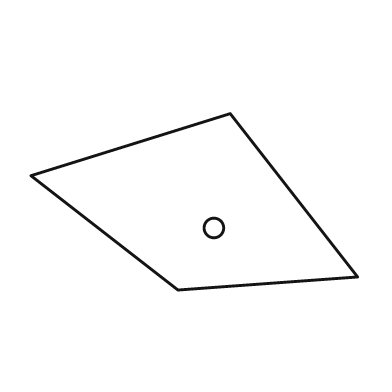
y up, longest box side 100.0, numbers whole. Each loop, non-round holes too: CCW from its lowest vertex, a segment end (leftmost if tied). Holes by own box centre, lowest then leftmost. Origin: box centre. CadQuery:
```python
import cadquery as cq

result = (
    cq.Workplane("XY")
    .moveTo(-5.0, -27.0)
    .lineTo(50.0, -23.0)
    .lineTo(11.0, 27.0)
    .lineTo(-50.0, 8.0)
    .close()
    .moveTo(6.0, -8.0)
    .circle(3.0)
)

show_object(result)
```